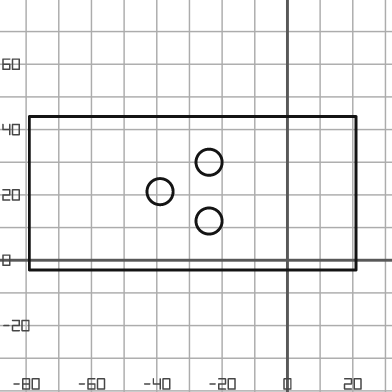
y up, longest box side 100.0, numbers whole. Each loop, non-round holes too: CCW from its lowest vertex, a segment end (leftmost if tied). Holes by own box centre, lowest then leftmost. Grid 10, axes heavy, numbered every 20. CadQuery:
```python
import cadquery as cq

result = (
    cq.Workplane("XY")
    .moveTo(-79.0, -3.0)
    .lineTo(21.0, -3.0)
    .lineTo(21.0, 44.0)
    .lineTo(-79.0, 44.0)
    .close()
    .moveTo(-24.0, 12.0)
    .circle(4.0)
    .moveTo(-39.0, 21.0)
    .circle(4.0)
    .moveTo(-24.0, 30.0)
    .circle(4.0)
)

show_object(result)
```